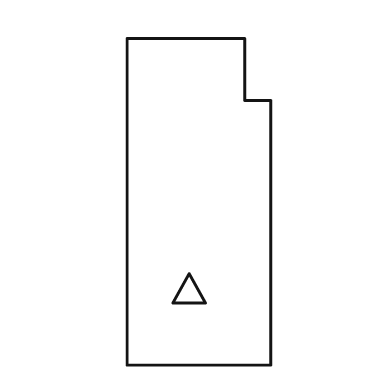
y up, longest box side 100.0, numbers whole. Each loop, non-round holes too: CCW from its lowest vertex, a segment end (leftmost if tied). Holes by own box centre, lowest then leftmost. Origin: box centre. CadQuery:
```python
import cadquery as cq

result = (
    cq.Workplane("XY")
    .moveTo(-22.0, -50.0)
    .lineTo(22.0, -50.0)
    .lineTo(22.0, 31.0)
    .lineTo(14.0, 31.0)
    .lineTo(14.0, 50.0)
    .lineTo(-22.0, 50.0)
    .close()
    .moveTo(-8.0, -31.0)
    .lineTo(2.0, -31.0)
    .lineTo(-3.0, -22.0)
    .close()
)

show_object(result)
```